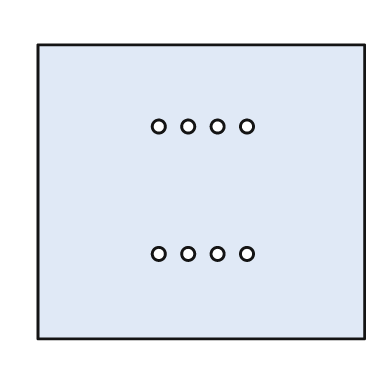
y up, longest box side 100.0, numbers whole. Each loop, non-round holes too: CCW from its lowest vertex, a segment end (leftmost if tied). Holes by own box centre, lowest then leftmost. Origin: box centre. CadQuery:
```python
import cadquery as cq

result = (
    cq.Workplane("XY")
    .moveTo(-50.0, -45.0)
    .lineTo(50.0, -45.0)
    .lineTo(50.0, 45.0)
    .lineTo(-50.0, 45.0)
    .close()
    .moveTo(-13.0, -19.0)
    .circle(2.0)
    .moveTo(-4.0, -19.0)
    .circle(2.0)
    .moveTo(5.0, -19.0)
    .circle(2.0)
    .moveTo(14.0, -19.0)
    .circle(2.0)
    .moveTo(-13.0, 20.0)
    .circle(2.0)
    .moveTo(-4.0, 20.0)
    .circle(2.0)
    .moveTo(5.0, 20.0)
    .circle(2.0)
    .moveTo(14.0, 20.0)
    .circle(2.0)
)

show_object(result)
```